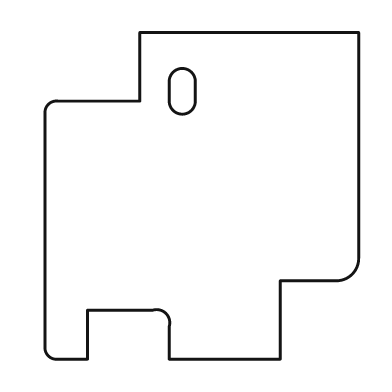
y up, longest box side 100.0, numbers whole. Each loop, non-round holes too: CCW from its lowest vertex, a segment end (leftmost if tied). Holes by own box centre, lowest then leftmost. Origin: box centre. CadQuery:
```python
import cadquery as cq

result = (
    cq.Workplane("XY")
    .moveTo(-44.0, -50.0)
    .lineTo(-35.0, -50.0)
    .lineTo(-35.0, -35.0)
    .lineTo(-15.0, -35.0)
    .threePointArc((-11.0, -36.0), (-10.0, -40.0))
    .lineTo(-10.0, -50.0)
    .lineTo(24.0, -50.0)
    .lineTo(24.0, -26.0)
    .lineTo(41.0, -26.0)
    .threePointArc((46.0, -24.0), (48.0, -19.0))
    .lineTo(48.0, 50.0)
    .lineTo(-19.0, 50.0)
    .lineTo(-19.0, 29.0)
    .lineTo(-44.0, 29.0)
    .threePointArc((-47.0, 28.0), (-48.0, 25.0))
    .lineTo(-48.0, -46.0)
    .threePointArc((-47.0, -49.0), (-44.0, -50.0))
    .close()
    .moveTo(-10.0, 29.0)
    .threePointArc((-6.0, 25.0), (-2.0, 29.0))
    .lineTo(-2.0, 35.0)
    .threePointArc((-6.0, 39.0), (-10.0, 35.0))
    .close()
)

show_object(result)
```